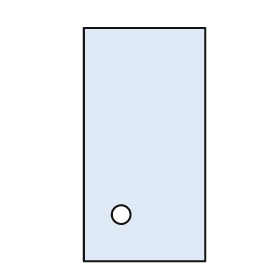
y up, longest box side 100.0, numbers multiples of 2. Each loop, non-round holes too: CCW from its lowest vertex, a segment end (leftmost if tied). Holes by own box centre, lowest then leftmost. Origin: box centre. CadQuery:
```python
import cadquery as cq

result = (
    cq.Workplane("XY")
    .moveTo(-26.0, -50.0)
    .lineTo(26.0, -50.0)
    .lineTo(26.0, 50.0)
    .lineTo(-26.0, 50.0)
    .close()
    .moveTo(-10.0, -30.0)
    .circle(4.0)
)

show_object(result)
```